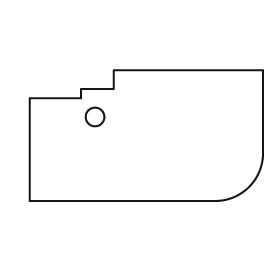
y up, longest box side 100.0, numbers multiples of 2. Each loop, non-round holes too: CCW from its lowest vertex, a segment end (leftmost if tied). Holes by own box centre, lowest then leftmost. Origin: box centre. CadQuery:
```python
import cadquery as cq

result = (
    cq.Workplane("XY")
    .moveTo(-50.0, -28.0)
    .lineTo(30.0, -28.0)
    .threePointArc((44.0, -22.0), (50.0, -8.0))
    .lineTo(50.0, 28.0)
    .lineTo(-14.0, 28.0)
    .lineTo(-14.0, 20.0)
    .lineTo(-28.0, 20.0)
    .lineTo(-28.0, 16.0)
    .lineTo(-50.0, 16.0)
    .close()
    .moveTo(-22.0, 8.0)
    .circle(4.0)
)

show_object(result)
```